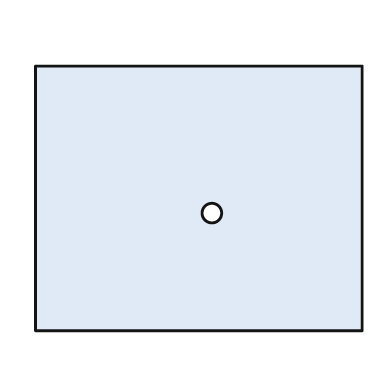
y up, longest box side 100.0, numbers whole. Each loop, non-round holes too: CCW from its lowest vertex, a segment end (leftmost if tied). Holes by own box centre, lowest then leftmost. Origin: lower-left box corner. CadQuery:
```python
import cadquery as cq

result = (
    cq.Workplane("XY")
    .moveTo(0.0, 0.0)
    .lineTo(100.0, 0.0)
    .lineTo(100.0, 81.0)
    .lineTo(0.0, 81.0)
    .close()
    .moveTo(54.0, 36.0)
    .circle(3.0)
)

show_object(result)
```